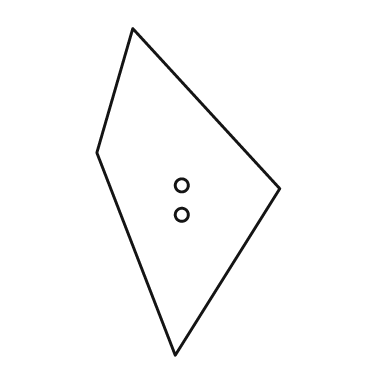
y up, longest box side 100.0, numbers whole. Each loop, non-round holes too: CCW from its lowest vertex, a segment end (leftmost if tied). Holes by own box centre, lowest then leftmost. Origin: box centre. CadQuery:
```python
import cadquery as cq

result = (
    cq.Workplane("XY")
    .moveTo(-4.0, -50.0)
    .lineTo(28.0, 1.0)
    .lineTo(-17.0, 50.0)
    .lineTo(-28.0, 12.0)
    .close()
    .moveTo(-2.0, -7.0)
    .circle(2.0)
    .moveTo(-2.0, 2.0)
    .circle(2.0)
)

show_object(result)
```